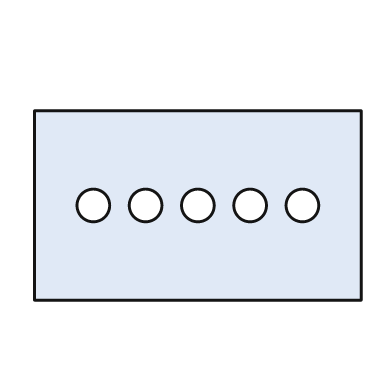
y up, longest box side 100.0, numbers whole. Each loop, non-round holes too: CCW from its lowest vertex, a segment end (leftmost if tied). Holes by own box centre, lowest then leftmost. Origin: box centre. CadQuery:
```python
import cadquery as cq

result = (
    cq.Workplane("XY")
    .moveTo(-50.0, -29.0)
    .lineTo(50.0, -29.0)
    .lineTo(50.0, 29.0)
    .lineTo(-50.0, 29.0)
    .close()
    .moveTo(-32.0, 0.0)
    .circle(5.0)
    .moveTo(-16.0, 0.0)
    .circle(5.0)
    .moveTo(0.0, 0.0)
    .circle(5.0)
    .moveTo(16.0, 0.0)
    .circle(5.0)
    .moveTo(32.0, 0.0)
    .circle(5.0)
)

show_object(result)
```